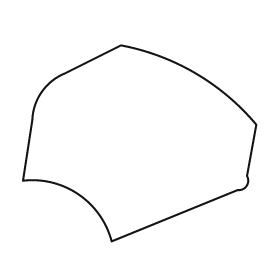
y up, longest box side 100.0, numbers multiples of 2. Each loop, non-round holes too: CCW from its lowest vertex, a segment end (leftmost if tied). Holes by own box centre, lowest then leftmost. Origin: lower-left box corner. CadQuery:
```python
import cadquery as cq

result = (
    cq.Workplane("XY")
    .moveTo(38.0, 0.0)
    .lineTo(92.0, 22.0)
    .threePointArc((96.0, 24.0), (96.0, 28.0))
    .lineTo(100.0, 50.0)
    .threePointArc((74.0, 72.0), (42.0, 84.0))
    .lineTo(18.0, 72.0)
    .threePointArc((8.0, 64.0), (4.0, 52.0))
    .lineTo(0.0, 26.0)
    .threePointArc((24.0, 20.0), (38.0, 0.0))
    .close()
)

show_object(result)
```